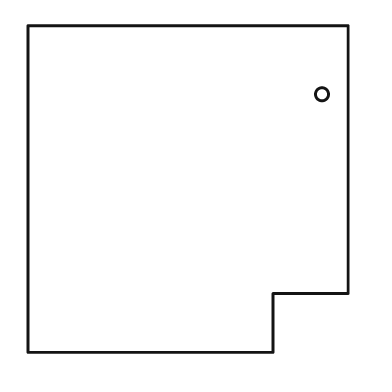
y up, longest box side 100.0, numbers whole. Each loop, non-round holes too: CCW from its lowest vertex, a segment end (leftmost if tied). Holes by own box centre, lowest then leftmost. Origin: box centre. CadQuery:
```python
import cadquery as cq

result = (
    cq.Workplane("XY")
    .moveTo(-49.0, -50.0)
    .lineTo(26.0, -50.0)
    .lineTo(26.0, -32.0)
    .lineTo(49.0, -32.0)
    .lineTo(49.0, 50.0)
    .lineTo(-49.0, 50.0)
    .close()
    .moveTo(41.0, 29.0)
    .circle(2.0)
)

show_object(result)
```